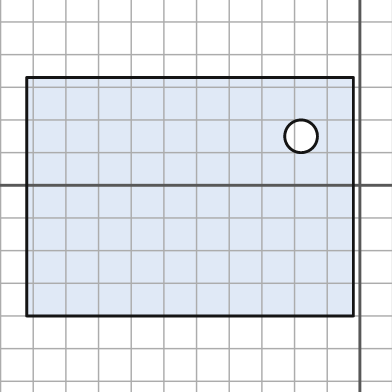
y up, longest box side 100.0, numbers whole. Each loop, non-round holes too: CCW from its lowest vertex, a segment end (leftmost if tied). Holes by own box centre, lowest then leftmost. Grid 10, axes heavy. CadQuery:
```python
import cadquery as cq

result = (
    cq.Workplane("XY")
    .moveTo(-102.0, -40.0)
    .lineTo(-2.0, -40.0)
    .lineTo(-2.0, 33.0)
    .lineTo(-102.0, 33.0)
    .close()
    .moveTo(-18.0, 15.0)
    .circle(5.0)
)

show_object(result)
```